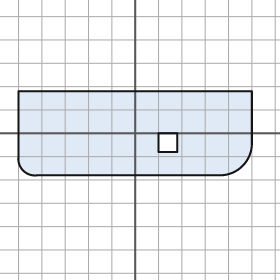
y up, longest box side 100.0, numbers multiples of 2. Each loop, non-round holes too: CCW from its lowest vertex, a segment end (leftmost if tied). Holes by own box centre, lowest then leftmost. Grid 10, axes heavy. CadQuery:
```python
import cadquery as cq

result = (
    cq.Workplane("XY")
    .moveTo(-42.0, -18.0)
    .lineTo(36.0, -18.0)
    .threePointArc((46.0, -14.0), (50.0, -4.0))
    .lineTo(50.0, 18.0)
    .lineTo(-50.0, 18.0)
    .lineTo(-50.0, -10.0)
    .threePointArc((-48.0, -16.0), (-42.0, -18.0))
    .close()
    .moveTo(10.0, -8.0)
    .lineTo(18.0, -8.0)
    .lineTo(18.0, 0.0)
    .lineTo(10.0, 0.0)
    .close()
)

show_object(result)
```